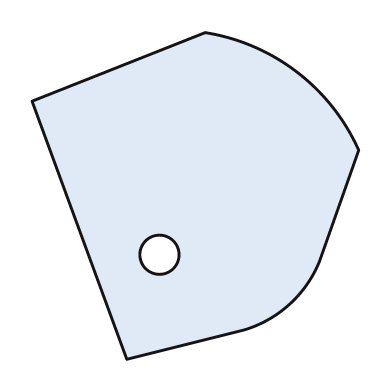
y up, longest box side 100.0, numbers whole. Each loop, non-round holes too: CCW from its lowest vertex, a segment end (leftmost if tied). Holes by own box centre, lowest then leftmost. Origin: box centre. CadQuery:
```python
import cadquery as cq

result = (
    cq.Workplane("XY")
    .moveTo(-21.0, -50.0)
    .lineTo(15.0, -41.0)
    .threePointArc((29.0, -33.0), (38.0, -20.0))
    .lineTo(50.0, 14.0)
    .threePointArc((31.0, 38.0), (3.0, 50.0))
    .lineTo(-50.0, 29.0)
    .close()
    .moveTo(-11.0, -18.0)
    .circle(6.0)
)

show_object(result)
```